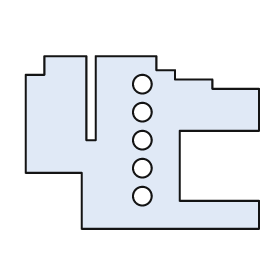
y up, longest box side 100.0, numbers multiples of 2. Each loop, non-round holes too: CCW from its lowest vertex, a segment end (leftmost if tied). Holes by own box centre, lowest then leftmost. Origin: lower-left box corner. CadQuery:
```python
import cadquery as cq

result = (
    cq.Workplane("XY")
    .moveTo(24.0, 0.0)
    .lineTo(100.0, 0.0)
    .lineTo(100.0, 12.0)
    .lineTo(66.0, 12.0)
    .lineTo(66.0, 42.0)
    .lineTo(100.0, 42.0)
    .lineTo(100.0, 60.0)
    .lineTo(80.0, 60.0)
    .lineTo(80.0, 64.0)
    .lineTo(64.0, 64.0)
    .lineTo(64.0, 68.0)
    .lineTo(56.0, 68.0)
    .lineTo(56.0, 74.0)
    .lineTo(30.0, 74.0)
    .lineTo(30.0, 38.0)
    .lineTo(26.0, 38.0)
    .lineTo(26.0, 74.0)
    .lineTo(8.0, 74.0)
    .lineTo(8.0, 66.0)
    .lineTo(0.0, 66.0)
    .lineTo(0.0, 24.0)
    .lineTo(24.0, 24.0)
    .close()
    .moveTo(50.0, 14.0)
    .circle(4.0)
    .moveTo(50.0, 26.0)
    .circle(4.0)
    .moveTo(50.0, 38.0)
    .circle(4.0)
    .moveTo(50.0, 50.0)
    .circle(4.0)
    .moveTo(50.0, 62.0)
    .circle(4.0)
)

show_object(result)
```